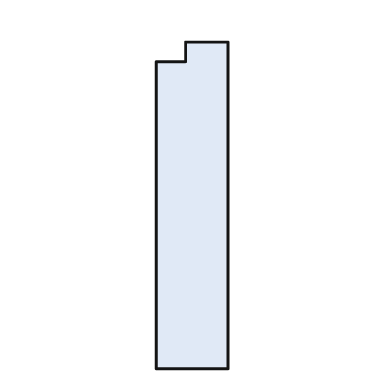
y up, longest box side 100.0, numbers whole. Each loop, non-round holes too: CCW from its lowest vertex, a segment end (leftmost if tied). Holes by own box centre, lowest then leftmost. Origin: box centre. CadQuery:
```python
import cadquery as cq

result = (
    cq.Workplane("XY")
    .moveTo(-11.0, -50.0)
    .lineTo(11.0, -50.0)
    .lineTo(11.0, 50.0)
    .lineTo(-2.0, 50.0)
    .lineTo(-2.0, 44.0)
    .lineTo(-11.0, 44.0)
    .close()
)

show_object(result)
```